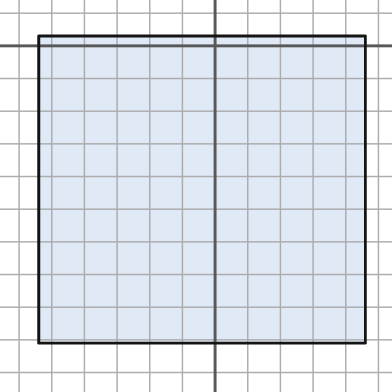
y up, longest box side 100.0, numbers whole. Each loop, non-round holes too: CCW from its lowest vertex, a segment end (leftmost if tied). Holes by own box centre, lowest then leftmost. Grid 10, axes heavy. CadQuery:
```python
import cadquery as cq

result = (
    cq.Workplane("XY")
    .moveTo(-54.0, -91.0)
    .lineTo(46.0, -91.0)
    .lineTo(46.0, 3.0)
    .lineTo(-54.0, 3.0)
    .close()
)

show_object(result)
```